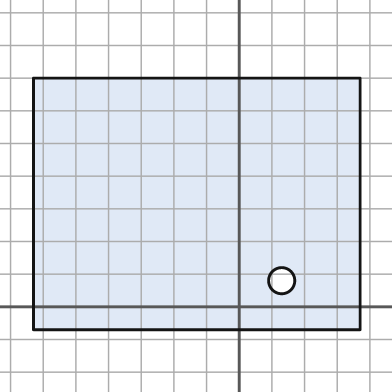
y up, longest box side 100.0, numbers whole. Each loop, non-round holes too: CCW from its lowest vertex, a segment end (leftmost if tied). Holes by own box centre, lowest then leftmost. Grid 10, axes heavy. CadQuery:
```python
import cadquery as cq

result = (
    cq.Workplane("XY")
    .moveTo(-63.0, -7.0)
    .lineTo(37.0, -7.0)
    .lineTo(37.0, 70.0)
    .lineTo(-63.0, 70.0)
    .close()
    .moveTo(13.0, 8.0)
    .circle(4.0)
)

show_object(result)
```